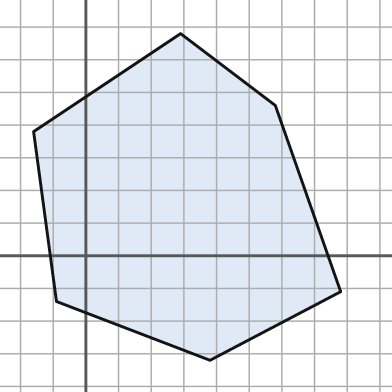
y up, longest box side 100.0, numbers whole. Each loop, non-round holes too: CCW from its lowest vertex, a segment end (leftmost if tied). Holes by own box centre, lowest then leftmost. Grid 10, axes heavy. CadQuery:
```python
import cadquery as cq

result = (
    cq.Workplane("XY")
    .moveTo(38.0, -32.0)
    .lineTo(78.0, -11.0)
    .lineTo(58.0, 46.0)
    .lineTo(29.0, 68.0)
    .lineTo(-16.0, 38.0)
    .lineTo(-9.0, -14.0)
    .close()
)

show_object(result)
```